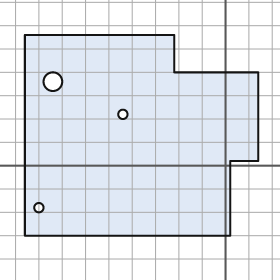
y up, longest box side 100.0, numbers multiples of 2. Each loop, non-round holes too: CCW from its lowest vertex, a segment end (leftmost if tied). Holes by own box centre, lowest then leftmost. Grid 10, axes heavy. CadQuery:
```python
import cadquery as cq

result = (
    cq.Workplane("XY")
    .moveTo(-86.0, -30.0)
    .lineTo(2.0, -30.0)
    .lineTo(2.0, 2.0)
    .lineTo(14.0, 2.0)
    .lineTo(14.0, 40.0)
    .lineTo(-22.0, 40.0)
    .lineTo(-22.0, 56.0)
    .lineTo(-86.0, 56.0)
    .close()
    .moveTo(-80.0, -18.0)
    .circle(2.0)
    .moveTo(-44.0, 22.0)
    .circle(2.0)
    .moveTo(-74.0, 36.0)
    .circle(4.0)
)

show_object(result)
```